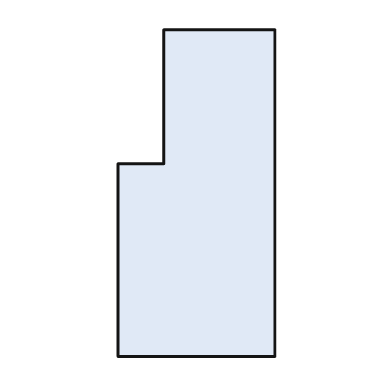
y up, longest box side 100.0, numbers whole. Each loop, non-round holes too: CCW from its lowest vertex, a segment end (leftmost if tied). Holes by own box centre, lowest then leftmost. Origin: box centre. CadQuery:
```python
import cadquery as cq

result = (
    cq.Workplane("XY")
    .moveTo(-24.0, -50.0)
    .lineTo(24.0, -50.0)
    .lineTo(24.0, 50.0)
    .lineTo(-10.0, 50.0)
    .lineTo(-10.0, 9.0)
    .lineTo(-24.0, 9.0)
    .close()
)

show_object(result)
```